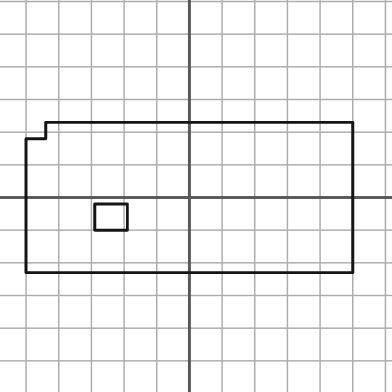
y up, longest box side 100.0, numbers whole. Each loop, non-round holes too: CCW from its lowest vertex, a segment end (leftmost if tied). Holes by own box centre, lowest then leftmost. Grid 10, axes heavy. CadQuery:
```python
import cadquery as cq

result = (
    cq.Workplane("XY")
    .moveTo(-50.0, -23.0)
    .lineTo(50.0, -23.0)
    .lineTo(50.0, 23.0)
    .lineTo(-44.0, 23.0)
    .lineTo(-44.0, 18.0)
    .lineTo(-50.0, 18.0)
    .close()
    .moveTo(-29.0, -10.0)
    .lineTo(-19.0, -10.0)
    .lineTo(-19.0, -2.0)
    .lineTo(-29.0, -2.0)
    .close()
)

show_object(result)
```